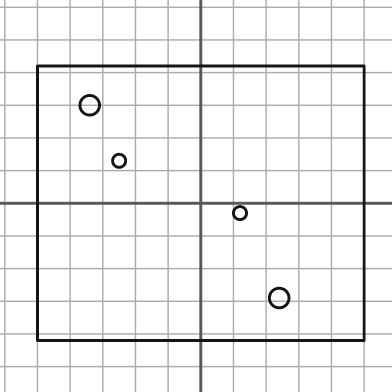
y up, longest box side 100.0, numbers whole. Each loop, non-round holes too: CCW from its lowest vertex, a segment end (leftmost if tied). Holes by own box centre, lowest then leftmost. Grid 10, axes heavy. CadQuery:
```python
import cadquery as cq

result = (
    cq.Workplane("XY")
    .moveTo(-50.0, -42.0)
    .lineTo(50.0, -42.0)
    .lineTo(50.0, 42.0)
    .lineTo(-50.0, 42.0)
    .close()
    .moveTo(24.0, -29.0)
    .circle(3.0)
    .moveTo(12.0, -3.0)
    .circle(2.0)
    .moveTo(-25.0, 13.0)
    .circle(2.0)
    .moveTo(-34.0, 30.0)
    .circle(3.0)
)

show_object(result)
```